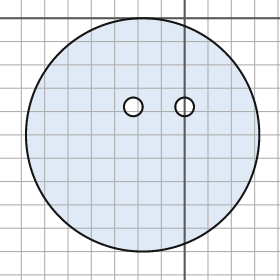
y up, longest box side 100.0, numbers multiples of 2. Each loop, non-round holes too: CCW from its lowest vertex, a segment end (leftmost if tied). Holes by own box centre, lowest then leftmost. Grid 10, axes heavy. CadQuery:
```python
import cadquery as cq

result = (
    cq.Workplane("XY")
    .moveTo(-18.0, -50.0)
    .circle(50.0)
    .moveTo(-22.0, -38.0)
    .circle(4.0)
    .moveTo(0.0, -38.0)
    .circle(4.0)
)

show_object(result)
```